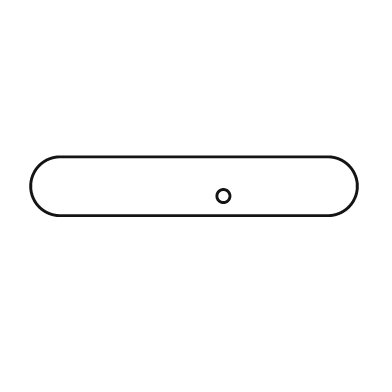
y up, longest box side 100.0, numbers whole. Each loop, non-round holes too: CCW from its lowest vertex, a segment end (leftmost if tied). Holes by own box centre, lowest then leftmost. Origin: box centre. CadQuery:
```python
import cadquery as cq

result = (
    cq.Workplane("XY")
    .moveTo(-41.0, -9.0)
    .lineTo(41.0, -9.0)
    .threePointArc((50.0, 0.0), (41.0, 9.0))
    .lineTo(-41.0, 9.0)
    .threePointArc((-50.0, 0.0), (-41.0, -9.0))
    .close()
    .moveTo(9.0, -3.0)
    .circle(2.0)
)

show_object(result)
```